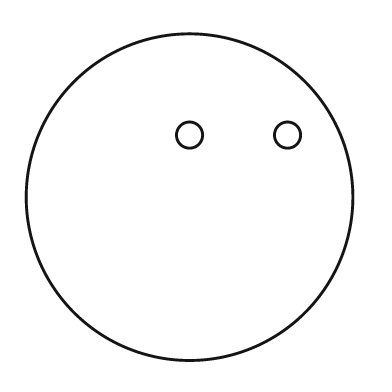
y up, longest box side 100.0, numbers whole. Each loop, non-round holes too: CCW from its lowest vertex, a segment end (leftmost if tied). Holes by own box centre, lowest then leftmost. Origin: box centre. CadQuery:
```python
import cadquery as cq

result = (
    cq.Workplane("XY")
    .moveTo(0.0, 0.0)
    .circle(50.0)
    .moveTo(0.0, 19.0)
    .circle(4.0)
    .moveTo(30.0, 19.0)
    .circle(4.0)
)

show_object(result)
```